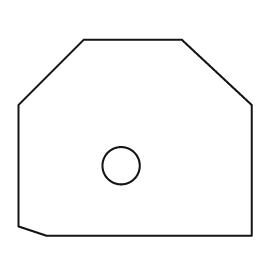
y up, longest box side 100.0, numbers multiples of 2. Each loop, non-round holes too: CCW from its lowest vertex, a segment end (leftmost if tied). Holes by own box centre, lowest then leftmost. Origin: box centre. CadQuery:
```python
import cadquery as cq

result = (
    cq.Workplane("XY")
    .moveTo(-38.0, -42.0)
    .lineTo(50.0, -42.0)
    .lineTo(50.0, 14.0)
    .lineTo(20.0, 42.0)
    .lineTo(-22.0, 42.0)
    .lineTo(-50.0, 14.0)
    .lineTo(-50.0, -38.0)
    .close()
    .moveTo(-6.0, -12.0)
    .circle(8.0)
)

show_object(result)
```